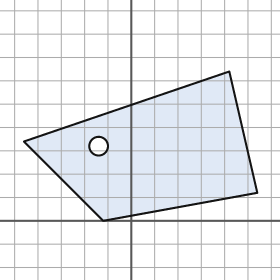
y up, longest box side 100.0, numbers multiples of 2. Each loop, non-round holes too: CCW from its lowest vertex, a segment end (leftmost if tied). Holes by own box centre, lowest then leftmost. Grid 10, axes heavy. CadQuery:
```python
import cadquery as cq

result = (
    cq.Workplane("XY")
    .moveTo(-12.0, 0.0)
    .lineTo(54.0, 12.0)
    .lineTo(42.0, 64.0)
    .lineTo(-46.0, 34.0)
    .close()
    .moveTo(-14.0, 32.0)
    .circle(4.0)
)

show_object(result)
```